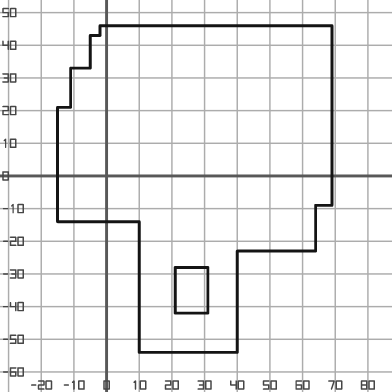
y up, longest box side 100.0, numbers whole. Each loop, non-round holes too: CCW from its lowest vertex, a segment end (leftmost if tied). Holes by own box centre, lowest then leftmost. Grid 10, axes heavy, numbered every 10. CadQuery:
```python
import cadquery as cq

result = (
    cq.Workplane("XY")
    .moveTo(10.0, -54.0)
    .lineTo(40.0, -54.0)
    .lineTo(40.0, -23.0)
    .lineTo(64.0, -23.0)
    .lineTo(64.0, -9.0)
    .lineTo(69.0, -9.0)
    .lineTo(69.0, 46.0)
    .lineTo(-2.0, 46.0)
    .lineTo(-2.0, 43.0)
    .lineTo(-5.0, 43.0)
    .lineTo(-5.0, 33.0)
    .lineTo(-11.0, 33.0)
    .lineTo(-11.0, 21.0)
    .lineTo(-15.0, 21.0)
    .lineTo(-15.0, -14.0)
    .lineTo(10.0, -14.0)
    .close()
    .moveTo(21.0, -42.0)
    .lineTo(31.0, -42.0)
    .lineTo(31.0, -28.0)
    .lineTo(21.0, -28.0)
    .close()
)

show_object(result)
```